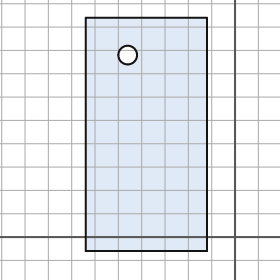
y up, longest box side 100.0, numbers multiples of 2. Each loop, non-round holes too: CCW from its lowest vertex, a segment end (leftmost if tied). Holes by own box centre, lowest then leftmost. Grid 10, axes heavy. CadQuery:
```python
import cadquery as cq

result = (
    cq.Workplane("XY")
    .moveTo(-64.0, -6.0)
    .lineTo(-12.0, -6.0)
    .lineTo(-12.0, 94.0)
    .lineTo(-64.0, 94.0)
    .close()
    .moveTo(-46.0, 78.0)
    .circle(4.0)
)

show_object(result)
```